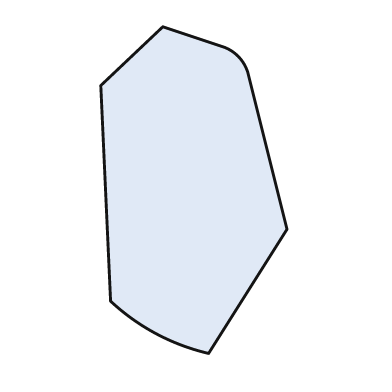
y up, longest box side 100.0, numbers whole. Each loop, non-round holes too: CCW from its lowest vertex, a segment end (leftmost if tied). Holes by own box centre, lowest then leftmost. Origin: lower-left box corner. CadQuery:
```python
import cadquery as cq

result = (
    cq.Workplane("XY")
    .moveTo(33.0, 0.0)
    .lineTo(57.0, 38.0)
    .lineTo(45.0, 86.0)
    .threePointArc((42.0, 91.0), (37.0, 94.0))
    .lineTo(19.0, 100.0)
    .lineTo(0.0, 82.0)
    .lineTo(3.0, 16.0)
    .threePointArc((17.0, 6.0), (33.0, 0.0))
    .close()
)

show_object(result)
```